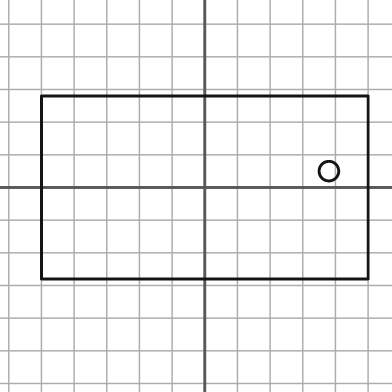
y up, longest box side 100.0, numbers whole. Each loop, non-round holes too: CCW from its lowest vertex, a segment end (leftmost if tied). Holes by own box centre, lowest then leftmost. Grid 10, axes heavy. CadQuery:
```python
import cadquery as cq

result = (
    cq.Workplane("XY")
    .moveTo(-50.0, -28.0)
    .lineTo(50.0, -28.0)
    .lineTo(50.0, 28.0)
    .lineTo(-50.0, 28.0)
    .close()
    .moveTo(38.0, 5.0)
    .circle(3.0)
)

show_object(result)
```